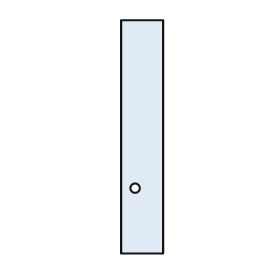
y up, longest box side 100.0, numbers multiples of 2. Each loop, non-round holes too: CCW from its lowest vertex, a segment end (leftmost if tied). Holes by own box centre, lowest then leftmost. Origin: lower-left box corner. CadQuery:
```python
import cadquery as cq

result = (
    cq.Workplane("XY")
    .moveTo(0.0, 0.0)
    .lineTo(18.0, 0.0)
    .lineTo(18.0, 100.0)
    .lineTo(0.0, 100.0)
    .close()
    .moveTo(6.0, 28.0)
    .circle(2.0)
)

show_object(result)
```